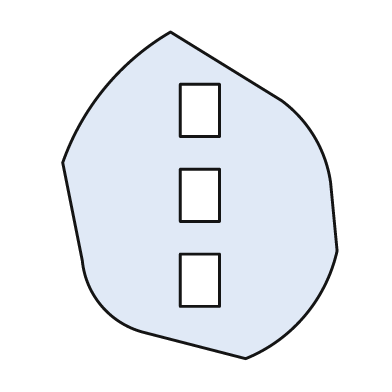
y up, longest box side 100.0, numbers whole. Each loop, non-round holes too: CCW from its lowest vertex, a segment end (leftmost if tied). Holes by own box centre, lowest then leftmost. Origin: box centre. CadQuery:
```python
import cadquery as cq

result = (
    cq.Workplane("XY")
    .moveTo(14.0, -50.0)
    .threePointArc((32.0, -37.0), (42.0, -17.0))
    .lineTo(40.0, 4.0)
    .threePointArc((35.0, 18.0), (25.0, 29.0))
    .lineTo(-9.0, 50.0)
    .threePointArc((-29.0, 33.0), (-42.0, 10.0))
    .lineTo(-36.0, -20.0)
    .threePointArc((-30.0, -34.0), (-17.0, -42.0))
    .close()
    .moveTo(-6.0, -34.0)
    .lineTo(6.0, -34.0)
    .lineTo(6.0, -18.0)
    .lineTo(-6.0, -18.0)
    .close()
    .moveTo(-6.0, -8.0)
    .lineTo(6.0, -8.0)
    .lineTo(6.0, 8.0)
    .lineTo(-6.0, 8.0)
    .close()
    .moveTo(-6.0, 18.0)
    .lineTo(6.0, 18.0)
    .lineTo(6.0, 34.0)
    .lineTo(-6.0, 34.0)
    .close()
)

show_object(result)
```